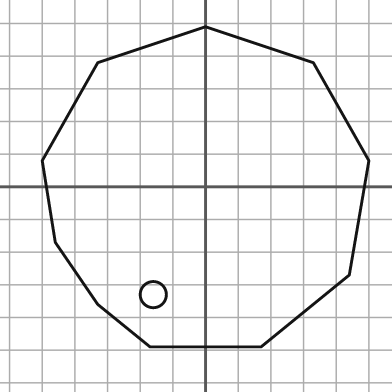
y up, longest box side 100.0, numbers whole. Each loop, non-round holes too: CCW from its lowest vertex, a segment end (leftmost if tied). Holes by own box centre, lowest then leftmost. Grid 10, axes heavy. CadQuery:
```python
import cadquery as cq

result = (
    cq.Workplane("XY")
    .moveTo(-17.0, -49.0)
    .lineTo(17.0, -49.0)
    .lineTo(44.0, -27.0)
    .lineTo(50.0, 8.0)
    .lineTo(33.0, 38.0)
    .lineTo(0.0, 49.0)
    .lineTo(-33.0, 38.0)
    .lineTo(-50.0, 8.0)
    .lineTo(-46.0, -17.0)
    .lineTo(-33.0, -36.0)
    .close()
    .moveTo(-16.0, -33.0)
    .circle(4.0)
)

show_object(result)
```